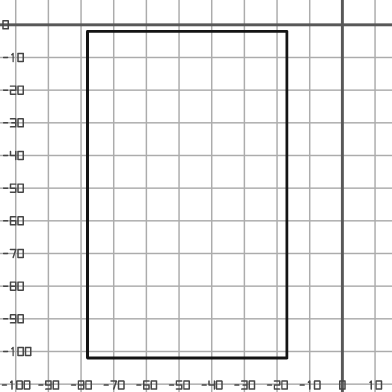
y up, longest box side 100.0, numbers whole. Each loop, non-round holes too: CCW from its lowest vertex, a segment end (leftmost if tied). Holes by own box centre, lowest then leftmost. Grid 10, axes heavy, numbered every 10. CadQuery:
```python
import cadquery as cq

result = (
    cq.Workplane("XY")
    .moveTo(-78.0, -102.0)
    .lineTo(-17.0, -102.0)
    .lineTo(-17.0, -2.0)
    .lineTo(-78.0, -2.0)
    .close()
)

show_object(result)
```